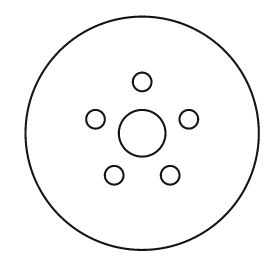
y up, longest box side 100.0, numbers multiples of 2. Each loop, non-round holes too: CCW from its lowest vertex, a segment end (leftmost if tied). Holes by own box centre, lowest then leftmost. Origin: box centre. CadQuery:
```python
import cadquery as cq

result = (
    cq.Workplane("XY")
    .moveTo(0.0, 0.0)
    .circle(50.0)
    .moveTo(-12.0, -18.0)
    .circle(4.0)
    .moveTo(12.0, -18.0)
    .circle(4.0)
    .moveTo(0.0, 0.0)
    .circle(10.0)
    .moveTo(-20.0, 6.0)
    .circle(4.0)
    .moveTo(20.0, 6.0)
    .circle(4.0)
    .moveTo(0.0, 22.0)
    .circle(4.0)
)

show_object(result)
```